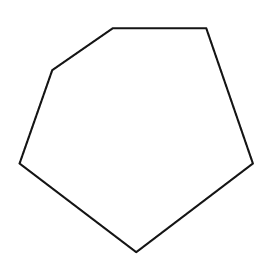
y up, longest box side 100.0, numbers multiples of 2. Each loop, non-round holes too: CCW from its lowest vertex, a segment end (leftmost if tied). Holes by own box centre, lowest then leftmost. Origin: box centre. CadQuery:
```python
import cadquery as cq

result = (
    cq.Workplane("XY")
    .moveTo(0.0, -48.0)
    .lineTo(50.0, -10.0)
    .lineTo(30.0, 48.0)
    .lineTo(-10.0, 48.0)
    .lineTo(-36.0, 30.0)
    .lineTo(-50.0, -10.0)
    .close()
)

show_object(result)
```